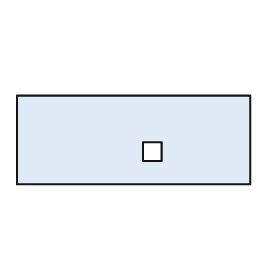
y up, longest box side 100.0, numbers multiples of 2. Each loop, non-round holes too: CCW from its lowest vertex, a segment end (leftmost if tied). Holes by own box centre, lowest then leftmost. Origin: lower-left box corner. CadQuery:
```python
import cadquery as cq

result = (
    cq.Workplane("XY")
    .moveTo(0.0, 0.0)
    .lineTo(100.0, 0.0)
    .lineTo(100.0, 38.0)
    .lineTo(0.0, 38.0)
    .close()
    .moveTo(54.0, 10.0)
    .lineTo(62.0, 10.0)
    .lineTo(62.0, 18.0)
    .lineTo(54.0, 18.0)
    .close()
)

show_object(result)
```